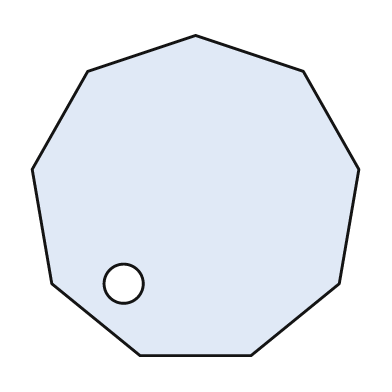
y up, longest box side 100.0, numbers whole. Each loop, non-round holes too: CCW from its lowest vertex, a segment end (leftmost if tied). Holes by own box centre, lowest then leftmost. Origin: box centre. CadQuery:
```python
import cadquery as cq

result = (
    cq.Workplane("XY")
    .moveTo(-17.0, -49.0)
    .lineTo(17.0, -49.0)
    .lineTo(44.0, -27.0)
    .lineTo(50.0, 8.0)
    .lineTo(33.0, 38.0)
    .lineTo(0.0, 49.0)
    .lineTo(-33.0, 38.0)
    .lineTo(-50.0, 8.0)
    .lineTo(-44.0, -27.0)
    .close()
    .moveTo(-22.0, -27.0)
    .circle(6.0)
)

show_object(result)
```